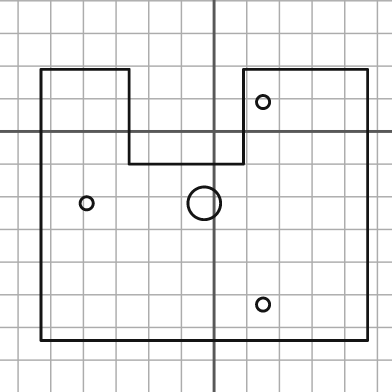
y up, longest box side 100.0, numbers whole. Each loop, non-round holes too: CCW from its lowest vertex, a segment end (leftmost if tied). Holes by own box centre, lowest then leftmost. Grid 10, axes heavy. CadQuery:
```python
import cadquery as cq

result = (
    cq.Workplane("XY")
    .moveTo(-53.0, -64.0)
    .lineTo(47.0, -64.0)
    .lineTo(47.0, 19.0)
    .lineTo(9.0, 19.0)
    .lineTo(9.0, -10.0)
    .lineTo(-26.0, -10.0)
    .lineTo(-26.0, 19.0)
    .lineTo(-53.0, 19.0)
    .close()
    .moveTo(15.0, -53.0)
    .circle(2.0)
    .moveTo(-39.0, -22.0)
    .circle(2.0)
    .moveTo(-3.0, -22.0)
    .circle(5.0)
    .moveTo(15.0, 9.0)
    .circle(2.0)
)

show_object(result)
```